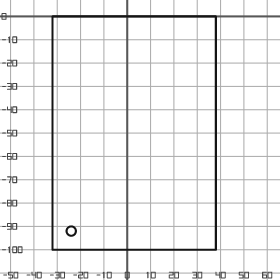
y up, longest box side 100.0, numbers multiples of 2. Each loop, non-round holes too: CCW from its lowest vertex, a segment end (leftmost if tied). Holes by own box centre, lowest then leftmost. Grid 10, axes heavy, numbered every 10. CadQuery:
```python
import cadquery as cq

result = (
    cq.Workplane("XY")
    .moveTo(-32.0, -100.0)
    .lineTo(38.0, -100.0)
    .lineTo(38.0, 0.0)
    .lineTo(-32.0, 0.0)
    .close()
    .moveTo(-24.0, -92.0)
    .circle(2.0)
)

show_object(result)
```